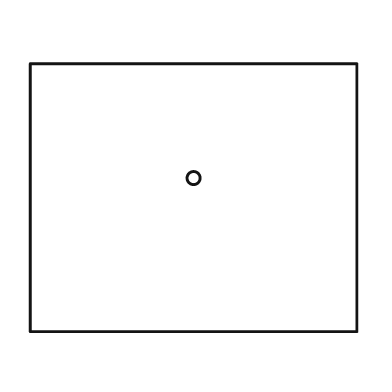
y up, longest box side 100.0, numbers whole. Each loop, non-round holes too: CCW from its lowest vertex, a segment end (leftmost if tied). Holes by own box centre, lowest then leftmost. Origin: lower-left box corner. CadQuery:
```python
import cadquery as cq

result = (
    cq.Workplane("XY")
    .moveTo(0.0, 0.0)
    .lineTo(100.0, 0.0)
    .lineTo(100.0, 82.0)
    .lineTo(0.0, 82.0)
    .close()
    .moveTo(50.0, 47.0)
    .circle(2.0)
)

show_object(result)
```